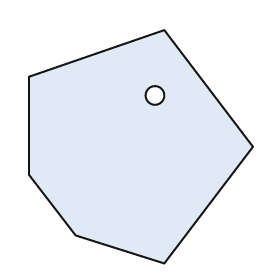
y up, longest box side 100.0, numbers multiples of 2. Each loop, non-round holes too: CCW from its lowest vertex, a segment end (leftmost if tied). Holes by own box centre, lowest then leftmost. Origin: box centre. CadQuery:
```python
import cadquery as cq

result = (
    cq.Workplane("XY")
    .moveTo(10.0, -50.0)
    .lineTo(48.0, 0.0)
    .lineTo(10.0, 50.0)
    .lineTo(-48.0, 30.0)
    .lineTo(-48.0, -12.0)
    .lineTo(-28.0, -38.0)
    .close()
    .moveTo(6.0, 22.0)
    .circle(4.0)
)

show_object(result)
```